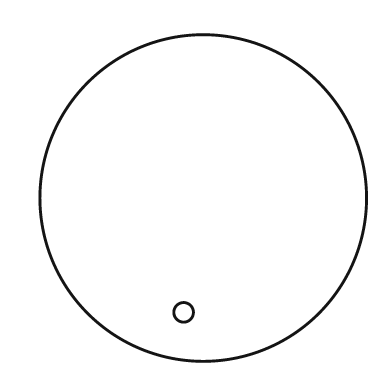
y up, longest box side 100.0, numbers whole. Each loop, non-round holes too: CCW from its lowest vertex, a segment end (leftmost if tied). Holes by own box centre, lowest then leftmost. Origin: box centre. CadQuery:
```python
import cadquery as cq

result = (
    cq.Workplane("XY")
    .moveTo(0.0, 0.0)
    .circle(50.0)
    .moveTo(-6.0, -35.0)
    .circle(3.0)
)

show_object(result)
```